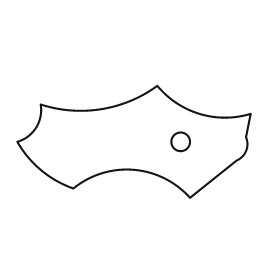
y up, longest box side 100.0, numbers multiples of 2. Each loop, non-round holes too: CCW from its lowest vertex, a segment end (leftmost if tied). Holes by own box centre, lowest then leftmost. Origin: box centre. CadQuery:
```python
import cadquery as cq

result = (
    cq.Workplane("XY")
    .moveTo(24.0, -24.0)
    .lineTo(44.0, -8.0)
    .threePointArc((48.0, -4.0), (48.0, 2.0))
    .lineTo(50.0, 12.0)
    .threePointArc((28.0, 12.0), (10.0, 24.0))
    .threePointArc((-14.0, 14.0), (-40.0, 16.0))
    .threePointArc((-42.0, 6.0), (-50.0, 0.0))
    .threePointArc((-40.0, -12.0), (-26.0, -20.0))
    .threePointArc((0.0, -12.0), (24.0, -24.0))
    .close()
    .moveTo(20.0, 0.0)
    .circle(4.0)
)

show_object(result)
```